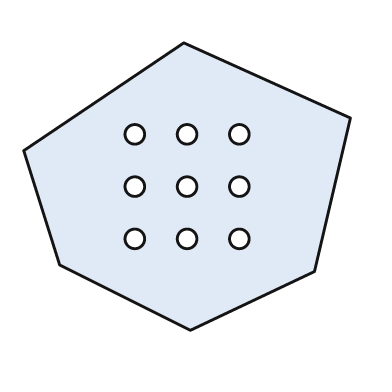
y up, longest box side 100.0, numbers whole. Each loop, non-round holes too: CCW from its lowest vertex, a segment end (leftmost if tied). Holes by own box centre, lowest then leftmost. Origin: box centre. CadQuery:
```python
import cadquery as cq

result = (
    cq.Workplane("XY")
    .moveTo(1.0, -44.0)
    .lineTo(39.0, -26.0)
    .lineTo(50.0, 21.0)
    .lineTo(-1.0, 44.0)
    .lineTo(-50.0, 11.0)
    .lineTo(-39.0, -24.0)
    .close()
    .moveTo(-16.0, -16.0)
    .circle(3.0)
    .moveTo(0.0, -16.0)
    .circle(3.0)
    .moveTo(16.0, -16.0)
    .circle(3.0)
    .moveTo(-16.0, 0.0)
    .circle(3.0)
    .moveTo(0.0, 0.0)
    .circle(3.0)
    .moveTo(16.0, 0.0)
    .circle(3.0)
    .moveTo(-16.0, 16.0)
    .circle(3.0)
    .moveTo(0.0, 16.0)
    .circle(3.0)
    .moveTo(16.0, 16.0)
    .circle(3.0)
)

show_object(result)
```